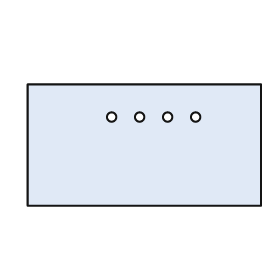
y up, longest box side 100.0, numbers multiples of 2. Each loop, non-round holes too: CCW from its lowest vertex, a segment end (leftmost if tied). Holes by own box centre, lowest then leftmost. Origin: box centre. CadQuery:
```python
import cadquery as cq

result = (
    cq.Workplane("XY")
    .moveTo(-50.0, -26.0)
    .lineTo(50.0, -26.0)
    .lineTo(50.0, 26.0)
    .lineTo(-50.0, 26.0)
    .close()
    .moveTo(-14.0, 12.0)
    .circle(2.0)
    .moveTo(-2.0, 12.0)
    .circle(2.0)
    .moveTo(10.0, 12.0)
    .circle(2.0)
    .moveTo(22.0, 12.0)
    .circle(2.0)
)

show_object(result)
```